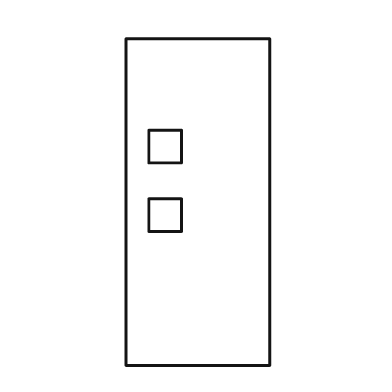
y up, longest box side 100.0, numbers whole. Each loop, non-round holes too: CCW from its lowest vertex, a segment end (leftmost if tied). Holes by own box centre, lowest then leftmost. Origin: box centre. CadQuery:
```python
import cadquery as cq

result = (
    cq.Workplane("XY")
    .moveTo(-22.0, -50.0)
    .lineTo(22.0, -50.0)
    .lineTo(22.0, 50.0)
    .lineTo(-22.0, 50.0)
    .close()
    .moveTo(-15.0, -9.0)
    .lineTo(-5.0, -9.0)
    .lineTo(-5.0, 1.0)
    .lineTo(-15.0, 1.0)
    .close()
    .moveTo(-15.0, 12.0)
    .lineTo(-5.0, 12.0)
    .lineTo(-5.0, 22.0)
    .lineTo(-15.0, 22.0)
    .close()
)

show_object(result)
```